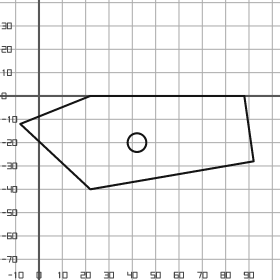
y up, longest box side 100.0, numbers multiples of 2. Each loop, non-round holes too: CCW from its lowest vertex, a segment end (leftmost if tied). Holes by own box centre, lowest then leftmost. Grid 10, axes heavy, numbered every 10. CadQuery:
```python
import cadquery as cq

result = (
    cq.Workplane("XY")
    .moveTo(22.0, -40.0)
    .lineTo(92.0, -28.0)
    .lineTo(88.0, 0.0)
    .lineTo(22.0, 0.0)
    .lineTo(-8.0, -12.0)
    .close()
    .moveTo(42.0, -20.0)
    .circle(4.0)
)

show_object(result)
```